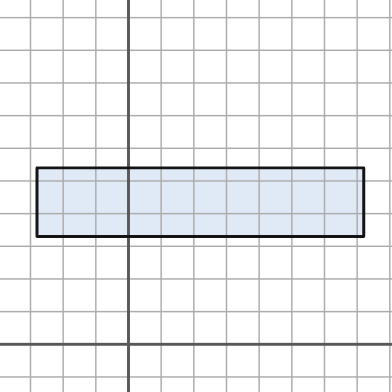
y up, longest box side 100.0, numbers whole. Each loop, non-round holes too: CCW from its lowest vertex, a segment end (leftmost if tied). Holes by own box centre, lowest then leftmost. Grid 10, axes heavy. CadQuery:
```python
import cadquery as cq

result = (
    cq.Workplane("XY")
    .moveTo(-28.0, 33.0)
    .lineTo(72.0, 33.0)
    .lineTo(72.0, 54.0)
    .lineTo(-28.0, 54.0)
    .close()
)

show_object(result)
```